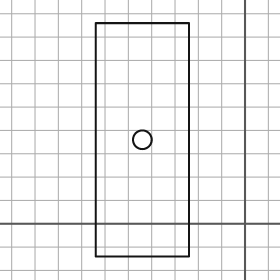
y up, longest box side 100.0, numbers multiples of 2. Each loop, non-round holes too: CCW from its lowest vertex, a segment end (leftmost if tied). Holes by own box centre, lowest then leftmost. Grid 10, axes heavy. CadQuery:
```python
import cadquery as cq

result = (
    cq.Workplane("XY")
    .moveTo(-64.0, -14.0)
    .lineTo(-24.0, -14.0)
    .lineTo(-24.0, 86.0)
    .lineTo(-64.0, 86.0)
    .close()
    .moveTo(-44.0, 36.0)
    .circle(4.0)
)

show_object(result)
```